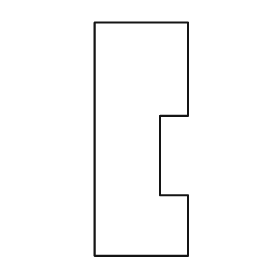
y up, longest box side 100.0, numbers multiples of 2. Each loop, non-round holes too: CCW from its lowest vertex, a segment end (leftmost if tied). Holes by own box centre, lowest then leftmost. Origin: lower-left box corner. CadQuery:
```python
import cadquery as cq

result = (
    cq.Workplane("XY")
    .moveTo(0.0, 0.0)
    .lineTo(40.0, 0.0)
    .lineTo(40.0, 26.0)
    .lineTo(28.0, 26.0)
    .lineTo(28.0, 60.0)
    .lineTo(40.0, 60.0)
    .lineTo(40.0, 100.0)
    .lineTo(0.0, 100.0)
    .close()
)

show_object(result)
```